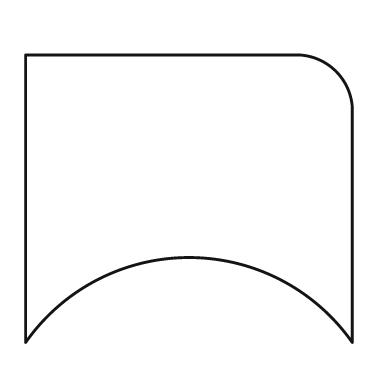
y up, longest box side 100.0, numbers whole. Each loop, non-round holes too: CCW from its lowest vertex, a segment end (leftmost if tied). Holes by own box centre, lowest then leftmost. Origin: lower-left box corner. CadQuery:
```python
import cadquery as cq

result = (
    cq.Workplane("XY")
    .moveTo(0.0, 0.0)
    .threePointArc((50.0, 26.0), (100.0, 0.0))
    .lineTo(100.0, 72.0)
    .threePointArc((95.0, 83.0), (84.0, 88.0))
    .lineTo(0.0, 88.0)
    .close()
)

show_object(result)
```